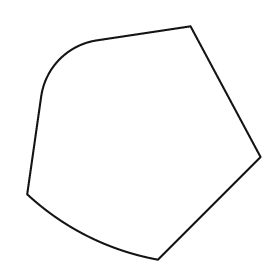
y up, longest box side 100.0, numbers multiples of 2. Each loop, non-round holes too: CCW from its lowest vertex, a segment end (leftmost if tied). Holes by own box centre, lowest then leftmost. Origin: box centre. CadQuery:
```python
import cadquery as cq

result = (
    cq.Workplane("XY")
    .moveTo(6.0, -50.0)
    .lineTo(50.0, -6.0)
    .lineTo(20.0, 50.0)
    .lineTo(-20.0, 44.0)
    .threePointArc((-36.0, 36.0), (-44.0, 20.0))
    .lineTo(-50.0, -22.0)
    .threePointArc((-24.0, -40.0), (6.0, -50.0))
    .close()
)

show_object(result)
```